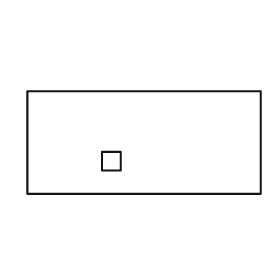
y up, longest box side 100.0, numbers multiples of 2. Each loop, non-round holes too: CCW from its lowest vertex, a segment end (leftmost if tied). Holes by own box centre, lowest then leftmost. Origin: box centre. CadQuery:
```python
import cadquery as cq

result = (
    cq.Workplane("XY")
    .moveTo(-50.0, -22.0)
    .lineTo(50.0, -22.0)
    .lineTo(50.0, 22.0)
    .lineTo(-50.0, 22.0)
    .close()
    .moveTo(-18.0, -12.0)
    .lineTo(-10.0, -12.0)
    .lineTo(-10.0, -4.0)
    .lineTo(-18.0, -4.0)
    .close()
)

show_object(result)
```